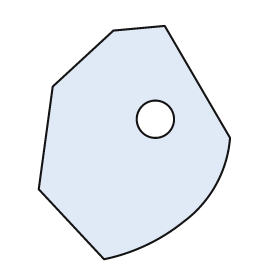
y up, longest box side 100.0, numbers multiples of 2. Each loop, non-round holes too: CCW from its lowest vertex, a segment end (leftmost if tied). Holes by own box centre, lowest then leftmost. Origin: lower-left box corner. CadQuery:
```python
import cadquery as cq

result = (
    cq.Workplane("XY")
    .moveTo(28.0, 0.0)
    .threePointArc((46.0, 6.0), (62.0, 16.0))
    .threePointArc((76.0, 32.0), (82.0, 52.0))
    .lineTo(54.0, 100.0)
    .lineTo(32.0, 98.0)
    .lineTo(6.0, 74.0)
    .lineTo(0.0, 30.0)
    .close()
    .moveTo(50.0, 60.0)
    .circle(8.0)
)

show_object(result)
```